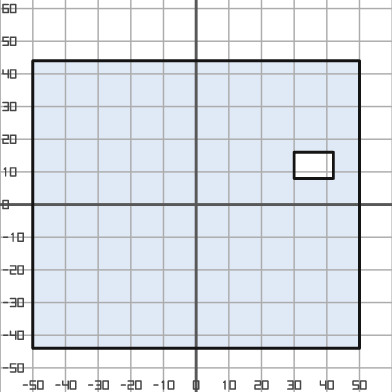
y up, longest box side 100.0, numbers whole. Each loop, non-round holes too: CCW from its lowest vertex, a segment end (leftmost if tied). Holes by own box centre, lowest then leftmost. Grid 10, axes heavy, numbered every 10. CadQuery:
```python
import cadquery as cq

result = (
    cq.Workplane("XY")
    .moveTo(-50.0, -44.0)
    .lineTo(50.0, -44.0)
    .lineTo(50.0, 44.0)
    .lineTo(-50.0, 44.0)
    .close()
    .moveTo(30.0, 8.0)
    .lineTo(42.0, 8.0)
    .lineTo(42.0, 16.0)
    .lineTo(30.0, 16.0)
    .close()
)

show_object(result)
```